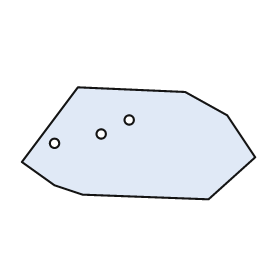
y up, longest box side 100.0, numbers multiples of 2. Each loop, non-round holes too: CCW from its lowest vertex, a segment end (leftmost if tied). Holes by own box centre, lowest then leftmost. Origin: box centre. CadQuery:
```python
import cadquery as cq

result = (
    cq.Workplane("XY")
    .moveTo(30.0, -24.0)
    .lineTo(50.0, -6.0)
    .lineTo(38.0, 12.0)
    .lineTo(20.0, 22.0)
    .lineTo(-26.0, 24.0)
    .lineTo(-50.0, -8.0)
    .lineTo(-36.0, -18.0)
    .lineTo(-24.0, -22.0)
    .close()
    .moveTo(-36.0, 0.0)
    .circle(2.0)
    .moveTo(-16.0, 4.0)
    .circle(2.0)
    .moveTo(-4.0, 10.0)
    .circle(2.0)
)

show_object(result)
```